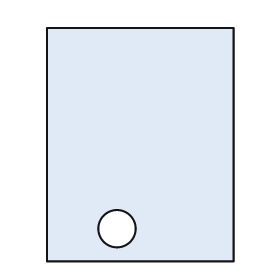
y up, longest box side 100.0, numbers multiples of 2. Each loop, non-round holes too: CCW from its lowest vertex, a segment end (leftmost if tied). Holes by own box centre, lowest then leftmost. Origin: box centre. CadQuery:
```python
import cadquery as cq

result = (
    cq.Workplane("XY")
    .moveTo(-40.0, -50.0)
    .lineTo(40.0, -50.0)
    .lineTo(40.0, 50.0)
    .lineTo(-40.0, 50.0)
    .close()
    .moveTo(-10.0, -36.0)
    .circle(8.0)
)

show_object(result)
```